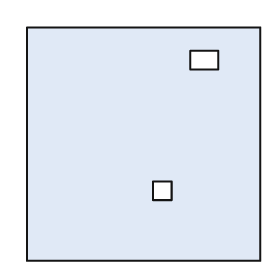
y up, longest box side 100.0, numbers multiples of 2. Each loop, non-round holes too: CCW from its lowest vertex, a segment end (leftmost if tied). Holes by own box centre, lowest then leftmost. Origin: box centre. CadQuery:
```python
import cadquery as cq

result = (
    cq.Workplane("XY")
    .moveTo(-50.0, -50.0)
    .lineTo(50.0, -50.0)
    .lineTo(50.0, 50.0)
    .lineTo(-50.0, 50.0)
    .close()
    .moveTo(4.0, -24.0)
    .lineTo(12.0, -24.0)
    .lineTo(12.0, -16.0)
    .lineTo(4.0, -16.0)
    .close()
    .moveTo(20.0, 32.0)
    .lineTo(32.0, 32.0)
    .lineTo(32.0, 40.0)
    .lineTo(20.0, 40.0)
    .close()
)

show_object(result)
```